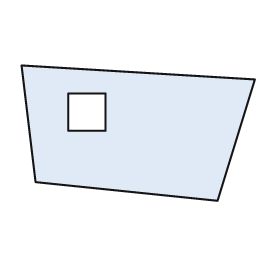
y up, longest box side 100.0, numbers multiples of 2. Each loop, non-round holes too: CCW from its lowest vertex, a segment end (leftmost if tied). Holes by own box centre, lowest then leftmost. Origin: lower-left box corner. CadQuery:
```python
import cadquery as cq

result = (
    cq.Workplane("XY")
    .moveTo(84.0, 0.0)
    .lineTo(100.0, 52.0)
    .lineTo(0.0, 58.0)
    .lineTo(6.0, 8.0)
    .close()
    .moveTo(20.0, 30.0)
    .lineTo(36.0, 30.0)
    .lineTo(36.0, 46.0)
    .lineTo(20.0, 46.0)
    .close()
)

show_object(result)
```